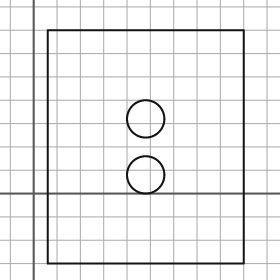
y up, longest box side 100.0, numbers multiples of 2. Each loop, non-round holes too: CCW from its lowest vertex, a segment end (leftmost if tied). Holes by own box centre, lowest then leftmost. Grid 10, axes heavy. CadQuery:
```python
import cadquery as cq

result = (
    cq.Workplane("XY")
    .moveTo(6.0, -30.0)
    .lineTo(90.0, -30.0)
    .lineTo(90.0, 70.0)
    .lineTo(6.0, 70.0)
    .close()
    .moveTo(48.0, 8.0)
    .circle(8.0)
    .moveTo(48.0, 32.0)
    .circle(8.0)
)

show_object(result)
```